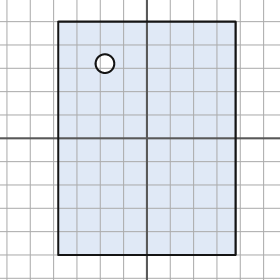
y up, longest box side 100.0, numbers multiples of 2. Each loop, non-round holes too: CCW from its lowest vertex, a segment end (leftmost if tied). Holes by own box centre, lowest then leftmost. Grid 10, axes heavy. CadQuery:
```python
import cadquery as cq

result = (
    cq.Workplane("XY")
    .moveTo(-38.0, -50.0)
    .lineTo(38.0, -50.0)
    .lineTo(38.0, 50.0)
    .lineTo(-38.0, 50.0)
    .close()
    .moveTo(-18.0, 32.0)
    .circle(4.0)
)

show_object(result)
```